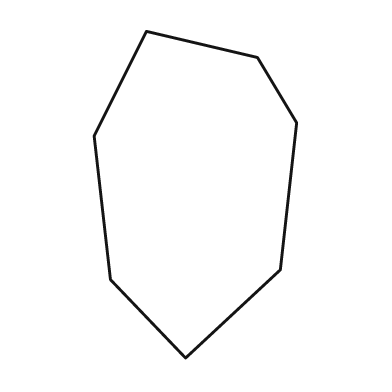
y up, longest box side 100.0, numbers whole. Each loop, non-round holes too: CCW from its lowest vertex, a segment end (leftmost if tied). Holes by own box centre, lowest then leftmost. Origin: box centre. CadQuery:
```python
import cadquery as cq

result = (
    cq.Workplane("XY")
    .moveTo(-3.0, -50.0)
    .lineTo(26.0, -23.0)
    .lineTo(31.0, 22.0)
    .lineTo(19.0, 42.0)
    .lineTo(-15.0, 50.0)
    .lineTo(-31.0, 18.0)
    .lineTo(-26.0, -26.0)
    .close()
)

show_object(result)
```